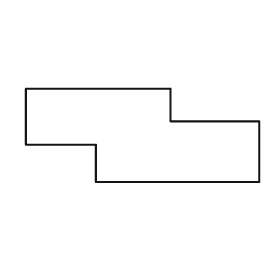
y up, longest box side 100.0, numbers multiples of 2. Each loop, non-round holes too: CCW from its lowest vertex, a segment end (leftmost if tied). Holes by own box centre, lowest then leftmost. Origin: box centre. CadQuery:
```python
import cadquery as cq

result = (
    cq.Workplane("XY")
    .moveTo(-20.0, -20.0)
    .lineTo(50.0, -20.0)
    .lineTo(50.0, 6.0)
    .lineTo(12.0, 6.0)
    .lineTo(12.0, 20.0)
    .lineTo(-50.0, 20.0)
    .lineTo(-50.0, -4.0)
    .lineTo(-20.0, -4.0)
    .close()
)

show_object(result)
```